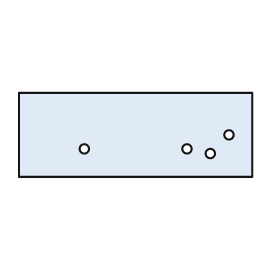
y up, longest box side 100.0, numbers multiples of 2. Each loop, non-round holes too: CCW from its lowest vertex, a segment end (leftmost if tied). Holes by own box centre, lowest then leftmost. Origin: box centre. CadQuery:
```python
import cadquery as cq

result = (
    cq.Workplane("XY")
    .moveTo(-50.0, -18.0)
    .lineTo(50.0, -18.0)
    .lineTo(50.0, 18.0)
    .lineTo(-50.0, 18.0)
    .close()
    .moveTo(32.0, -8.0)
    .circle(2.0)
    .moveTo(-22.0, -6.0)
    .circle(2.0)
    .moveTo(22.0, -6.0)
    .circle(2.0)
    .moveTo(40.0, 0.0)
    .circle(2.0)
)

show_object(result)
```